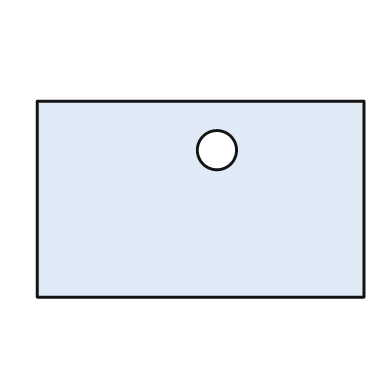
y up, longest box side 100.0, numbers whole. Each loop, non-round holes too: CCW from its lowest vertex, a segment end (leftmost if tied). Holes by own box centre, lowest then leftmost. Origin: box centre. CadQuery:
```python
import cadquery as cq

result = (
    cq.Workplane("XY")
    .moveTo(-50.0, -30.0)
    .lineTo(50.0, -30.0)
    .lineTo(50.0, 30.0)
    .lineTo(-50.0, 30.0)
    .close()
    .moveTo(5.0, 15.0)
    .circle(6.0)
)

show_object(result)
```